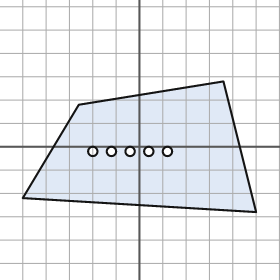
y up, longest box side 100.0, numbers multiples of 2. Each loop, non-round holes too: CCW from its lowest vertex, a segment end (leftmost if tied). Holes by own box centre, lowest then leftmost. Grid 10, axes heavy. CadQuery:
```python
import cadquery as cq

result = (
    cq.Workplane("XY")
    .moveTo(50.0, -28.0)
    .lineTo(36.0, 28.0)
    .lineTo(-26.0, 18.0)
    .lineTo(-50.0, -22.0)
    .close()
    .moveTo(-20.0, -2.0)
    .circle(2.0)
    .moveTo(-12.0, -2.0)
    .circle(2.0)
    .moveTo(-4.0, -2.0)
    .circle(2.0)
    .moveTo(4.0, -2.0)
    .circle(2.0)
    .moveTo(12.0, -2.0)
    .circle(2.0)
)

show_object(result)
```